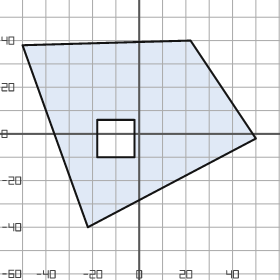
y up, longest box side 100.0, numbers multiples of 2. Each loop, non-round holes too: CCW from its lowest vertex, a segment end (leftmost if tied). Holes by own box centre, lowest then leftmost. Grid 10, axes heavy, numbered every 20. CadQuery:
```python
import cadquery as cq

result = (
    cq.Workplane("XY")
    .moveTo(-22.0, -40.0)
    .lineTo(50.0, -2.0)
    .lineTo(22.0, 40.0)
    .lineTo(-50.0, 38.0)
    .close()
    .moveTo(-18.0, -10.0)
    .lineTo(-2.0, -10.0)
    .lineTo(-2.0, 6.0)
    .lineTo(-18.0, 6.0)
    .close()
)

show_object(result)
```